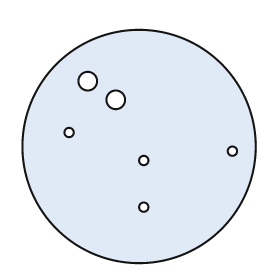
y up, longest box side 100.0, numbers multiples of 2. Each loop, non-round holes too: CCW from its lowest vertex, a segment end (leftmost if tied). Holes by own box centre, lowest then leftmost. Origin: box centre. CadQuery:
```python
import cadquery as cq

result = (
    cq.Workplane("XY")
    .moveTo(0.0, 0.0)
    .circle(50.0)
    .moveTo(2.0, -26.0)
    .circle(2.0)
    .moveTo(2.0, -6.0)
    .circle(2.0)
    .moveTo(40.0, -2.0)
    .circle(2.0)
    .moveTo(-30.0, 6.0)
    .circle(2.0)
    .moveTo(-10.0, 20.0)
    .circle(4.0)
    .moveTo(-22.0, 28.0)
    .circle(4.0)
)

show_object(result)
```